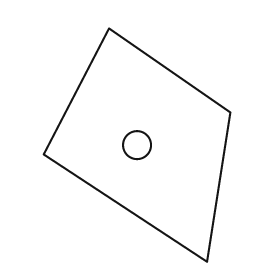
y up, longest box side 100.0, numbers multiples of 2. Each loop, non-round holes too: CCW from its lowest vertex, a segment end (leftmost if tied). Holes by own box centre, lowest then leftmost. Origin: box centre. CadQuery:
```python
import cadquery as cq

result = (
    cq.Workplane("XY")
    .moveTo(30.0, -50.0)
    .lineTo(40.0, 14.0)
    .lineTo(-12.0, 50.0)
    .lineTo(-40.0, -4.0)
    .close()
    .moveTo(0.0, 0.0)
    .circle(6.0)
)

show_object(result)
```